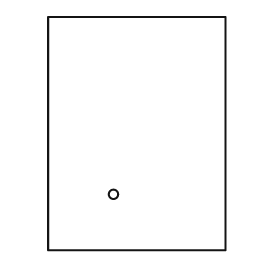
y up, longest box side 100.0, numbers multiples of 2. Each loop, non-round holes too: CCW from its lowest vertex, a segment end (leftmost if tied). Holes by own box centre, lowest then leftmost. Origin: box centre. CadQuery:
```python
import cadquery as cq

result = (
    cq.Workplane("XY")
    .moveTo(-38.0, -50.0)
    .lineTo(38.0, -50.0)
    .lineTo(38.0, 50.0)
    .lineTo(-38.0, 50.0)
    .close()
    .moveTo(-10.0, -26.0)
    .circle(2.0)
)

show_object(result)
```